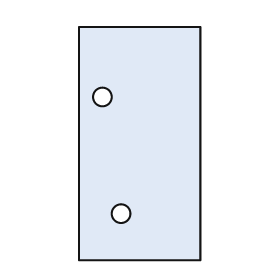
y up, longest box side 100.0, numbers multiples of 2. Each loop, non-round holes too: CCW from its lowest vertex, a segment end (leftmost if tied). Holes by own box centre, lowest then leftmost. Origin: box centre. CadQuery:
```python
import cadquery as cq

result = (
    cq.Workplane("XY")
    .moveTo(-26.0, -50.0)
    .lineTo(26.0, -50.0)
    .lineTo(26.0, 50.0)
    .lineTo(-26.0, 50.0)
    .close()
    .moveTo(-8.0, -30.0)
    .circle(4.0)
    .moveTo(-16.0, 20.0)
    .circle(4.0)
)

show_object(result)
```